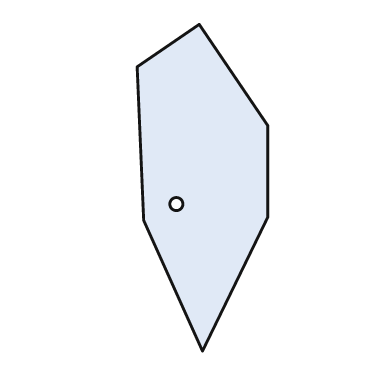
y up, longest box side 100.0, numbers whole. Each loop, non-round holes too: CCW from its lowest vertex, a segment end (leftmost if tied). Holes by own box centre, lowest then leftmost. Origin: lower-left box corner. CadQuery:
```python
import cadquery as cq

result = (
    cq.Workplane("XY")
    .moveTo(20.0, 0.0)
    .lineTo(40.0, 41.0)
    .lineTo(40.0, 69.0)
    .lineTo(19.0, 100.0)
    .lineTo(0.0, 87.0)
    .lineTo(2.0, 40.0)
    .close()
    .moveTo(12.0, 45.0)
    .circle(2.0)
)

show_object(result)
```